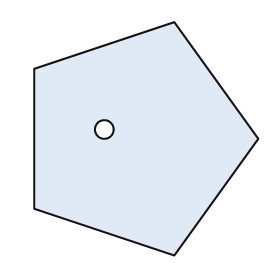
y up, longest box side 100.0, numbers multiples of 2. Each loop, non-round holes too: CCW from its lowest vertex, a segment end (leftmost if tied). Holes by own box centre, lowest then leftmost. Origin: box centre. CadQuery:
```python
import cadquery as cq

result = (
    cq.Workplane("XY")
    .moveTo(12.0, -50.0)
    .lineTo(48.0, 0.0)
    .lineTo(12.0, 50.0)
    .lineTo(-48.0, 30.0)
    .lineTo(-48.0, -30.0)
    .close()
    .moveTo(-18.0, 4.0)
    .circle(4.0)
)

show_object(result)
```